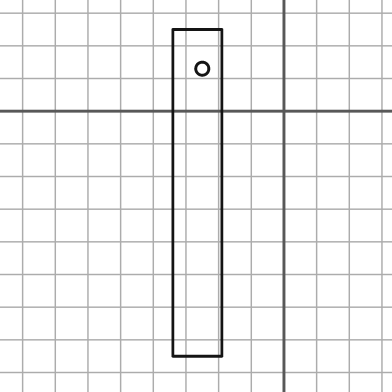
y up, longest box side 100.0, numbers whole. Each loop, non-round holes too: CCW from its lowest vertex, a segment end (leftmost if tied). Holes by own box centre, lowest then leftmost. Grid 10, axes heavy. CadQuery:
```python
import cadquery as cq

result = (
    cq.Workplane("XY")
    .moveTo(-34.0, -75.0)
    .lineTo(-19.0, -75.0)
    .lineTo(-19.0, 25.0)
    .lineTo(-34.0, 25.0)
    .close()
    .moveTo(-25.0, 13.0)
    .circle(2.0)
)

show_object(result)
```